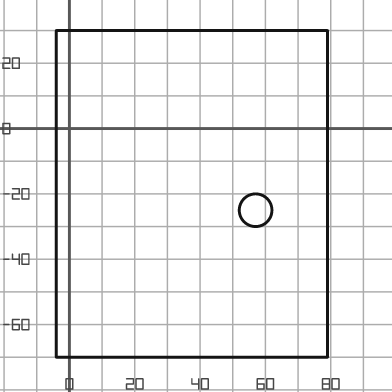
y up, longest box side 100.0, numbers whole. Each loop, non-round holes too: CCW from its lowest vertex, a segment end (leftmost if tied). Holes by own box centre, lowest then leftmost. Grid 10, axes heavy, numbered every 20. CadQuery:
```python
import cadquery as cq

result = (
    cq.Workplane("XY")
    .moveTo(-4.0, -70.0)
    .lineTo(79.0, -70.0)
    .lineTo(79.0, 30.0)
    .lineTo(-4.0, 30.0)
    .close()
    .moveTo(57.0, -25.0)
    .circle(5.0)
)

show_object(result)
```